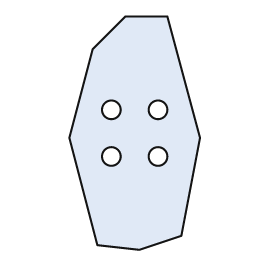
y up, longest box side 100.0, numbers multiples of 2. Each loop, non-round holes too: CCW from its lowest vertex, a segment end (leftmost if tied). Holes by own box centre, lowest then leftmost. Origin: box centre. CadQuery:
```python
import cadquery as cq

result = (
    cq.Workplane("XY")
    .moveTo(2.0, -50.0)
    .lineTo(20.0, -44.0)
    .lineTo(28.0, -2.0)
    .lineTo(14.0, 50.0)
    .lineTo(-4.0, 50.0)
    .lineTo(-18.0, 36.0)
    .lineTo(-28.0, -2.0)
    .lineTo(-16.0, -48.0)
    .close()
    .moveTo(-10.0, -10.0)
    .circle(4.0)
    .moveTo(10.0, -10.0)
    .circle(4.0)
    .moveTo(-10.0, 10.0)
    .circle(4.0)
    .moveTo(10.0, 10.0)
    .circle(4.0)
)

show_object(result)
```